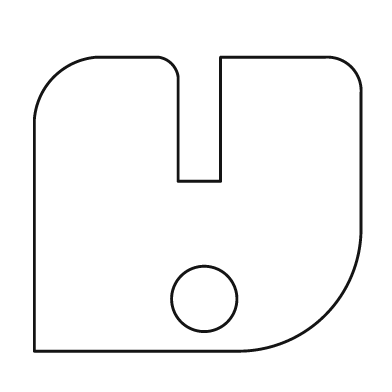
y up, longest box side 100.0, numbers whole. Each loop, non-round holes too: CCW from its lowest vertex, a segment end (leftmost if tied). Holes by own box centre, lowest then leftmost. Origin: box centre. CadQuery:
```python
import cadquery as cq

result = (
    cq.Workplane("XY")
    .moveTo(-50.0, -45.0)
    .lineTo(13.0, -45.0)
    .threePointArc((39.0, -34.0), (50.0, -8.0))
    .lineTo(50.0, 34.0)
    .threePointArc((47.0, 42.0), (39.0, 45.0))
    .lineTo(7.0, 45.0)
    .lineTo(7.0, 7.0)
    .lineTo(-6.0, 7.0)
    .lineTo(-6.0, 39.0)
    .threePointArc((-8.0, 43.0), (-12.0, 45.0))
    .lineTo(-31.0, 45.0)
    .threePointArc((-44.0, 39.0), (-50.0, 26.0))
    .close()
    .moveTo(2.0, -29.0)
    .circle(10.0)
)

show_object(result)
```